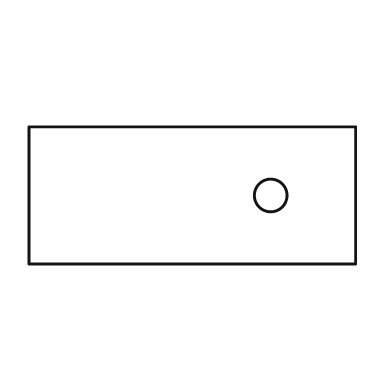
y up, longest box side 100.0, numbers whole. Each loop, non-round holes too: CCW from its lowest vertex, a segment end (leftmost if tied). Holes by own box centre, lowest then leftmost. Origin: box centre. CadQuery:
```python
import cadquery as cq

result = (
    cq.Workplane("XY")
    .moveTo(-50.0, -21.0)
    .lineTo(50.0, -21.0)
    .lineTo(50.0, 21.0)
    .lineTo(-50.0, 21.0)
    .close()
    .moveTo(24.0, 0.0)
    .circle(5.0)
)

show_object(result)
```